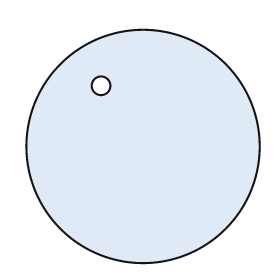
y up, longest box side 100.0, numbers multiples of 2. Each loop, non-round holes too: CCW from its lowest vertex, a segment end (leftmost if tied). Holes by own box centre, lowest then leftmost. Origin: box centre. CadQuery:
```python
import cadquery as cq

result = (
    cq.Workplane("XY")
    .moveTo(0.0, 0.0)
    .circle(50.0)
    .moveTo(-18.0, 26.0)
    .circle(4.0)
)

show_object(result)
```